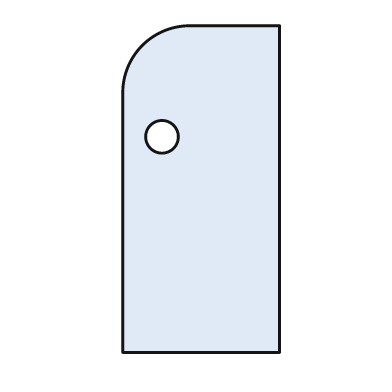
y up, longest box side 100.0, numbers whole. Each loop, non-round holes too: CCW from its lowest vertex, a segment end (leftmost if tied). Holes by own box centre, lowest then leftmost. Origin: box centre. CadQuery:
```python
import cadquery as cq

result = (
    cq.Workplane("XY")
    .moveTo(-24.0, -50.0)
    .lineTo(24.0, -50.0)
    .lineTo(24.0, 50.0)
    .lineTo(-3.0, 50.0)
    .threePointArc((-18.0, 44.0), (-24.0, 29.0))
    .close()
    .moveTo(-12.0, 16.0)
    .circle(5.0)
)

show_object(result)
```